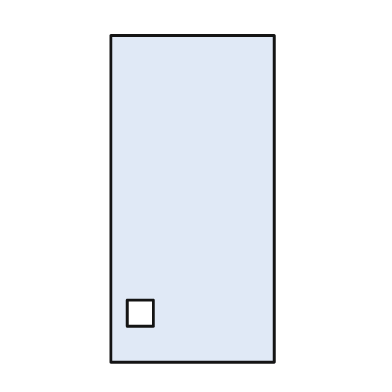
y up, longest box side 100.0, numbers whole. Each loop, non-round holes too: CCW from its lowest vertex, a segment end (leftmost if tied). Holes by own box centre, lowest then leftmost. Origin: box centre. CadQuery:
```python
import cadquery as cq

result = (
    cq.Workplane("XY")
    .moveTo(-25.0, -50.0)
    .lineTo(25.0, -50.0)
    .lineTo(25.0, 50.0)
    .lineTo(-25.0, 50.0)
    .close()
    .moveTo(-20.0, -39.0)
    .lineTo(-12.0, -39.0)
    .lineTo(-12.0, -31.0)
    .lineTo(-20.0, -31.0)
    .close()
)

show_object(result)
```